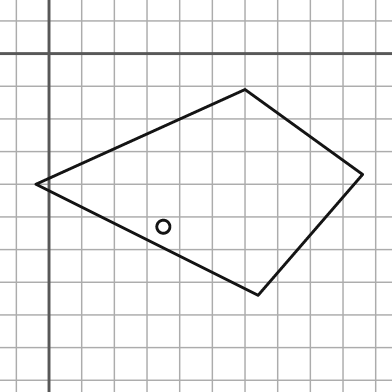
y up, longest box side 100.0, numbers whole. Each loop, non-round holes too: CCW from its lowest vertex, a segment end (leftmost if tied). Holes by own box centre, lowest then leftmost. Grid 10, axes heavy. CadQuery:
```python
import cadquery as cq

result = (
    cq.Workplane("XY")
    .moveTo(64.0, -74.0)
    .lineTo(96.0, -37.0)
    .lineTo(60.0, -11.0)
    .lineTo(-4.0, -40.0)
    .close()
    .moveTo(35.0, -53.0)
    .circle(2.0)
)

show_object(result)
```